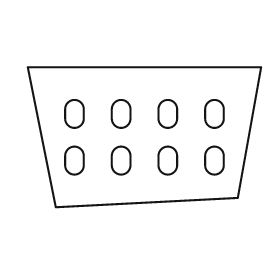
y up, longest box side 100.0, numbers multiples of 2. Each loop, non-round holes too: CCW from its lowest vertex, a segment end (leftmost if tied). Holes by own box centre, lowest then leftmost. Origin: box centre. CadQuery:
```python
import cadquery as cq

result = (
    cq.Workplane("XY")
    .moveTo(-38.0, -30.0)
    .lineTo(40.0, -26.0)
    .lineTo(50.0, 30.0)
    .lineTo(-50.0, 30.0)
    .close()
    .moveTo(-34.0, -12.0)
    .threePointArc((-30.0, -16.0), (-26.0, -12.0))
    .lineTo(-26.0, -8.0)
    .threePointArc((-30.0, -4.0), (-34.0, -8.0))
    .close()
    .moveTo(-14.0, -12.0)
    .threePointArc((-10.0, -16.0), (-6.0, -12.0))
    .lineTo(-6.0, -8.0)
    .threePointArc((-10.0, -4.0), (-14.0, -8.0))
    .close()
    .moveTo(6.0, -12.0)
    .threePointArc((10.0, -16.0), (14.0, -12.0))
    .lineTo(14.0, -8.0)
    .threePointArc((10.0, -4.0), (6.0, -8.0))
    .close()
    .moveTo(26.0, -12.0)
    .threePointArc((30.0, -16.0), (34.0, -12.0))
    .lineTo(34.0, -8.0)
    .threePointArc((30.0, -4.0), (26.0, -8.0))
    .close()
    .moveTo(-34.0, 8.0)
    .threePointArc((-30.0, 4.0), (-26.0, 8.0))
    .lineTo(-26.0, 12.0)
    .threePointArc((-30.0, 16.0), (-34.0, 12.0))
    .close()
    .moveTo(-14.0, 8.0)
    .threePointArc((-10.0, 4.0), (-6.0, 8.0))
    .lineTo(-6.0, 12.0)
    .threePointArc((-10.0, 16.0), (-14.0, 12.0))
    .close()
    .moveTo(6.0, 8.0)
    .threePointArc((10.0, 4.0), (14.0, 8.0))
    .lineTo(14.0, 12.0)
    .threePointArc((10.0, 16.0), (6.0, 12.0))
    .close()
    .moveTo(26.0, 8.0)
    .threePointArc((30.0, 4.0), (34.0, 8.0))
    .lineTo(34.0, 12.0)
    .threePointArc((30.0, 16.0), (26.0, 12.0))
    .close()
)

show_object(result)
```